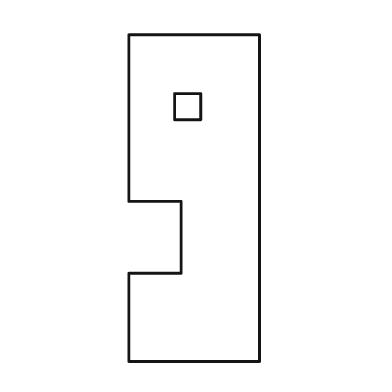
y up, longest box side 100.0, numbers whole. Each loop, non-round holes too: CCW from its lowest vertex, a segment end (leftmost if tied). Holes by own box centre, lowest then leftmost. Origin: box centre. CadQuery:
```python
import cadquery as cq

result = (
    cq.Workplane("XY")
    .moveTo(-20.0, -50.0)
    .lineTo(20.0, -50.0)
    .lineTo(20.0, 50.0)
    .lineTo(-20.0, 50.0)
    .lineTo(-20.0, -1.0)
    .lineTo(-4.0, -1.0)
    .lineTo(-4.0, -23.0)
    .lineTo(-20.0, -23.0)
    .close()
    .moveTo(-6.0, 24.0)
    .lineTo(2.0, 24.0)
    .lineTo(2.0, 32.0)
    .lineTo(-6.0, 32.0)
    .close()
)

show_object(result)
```